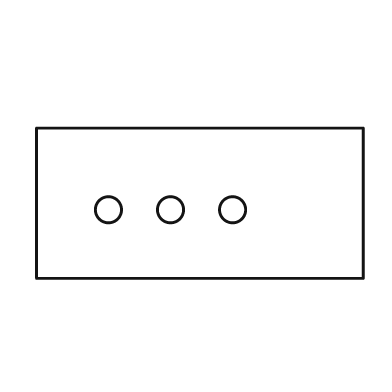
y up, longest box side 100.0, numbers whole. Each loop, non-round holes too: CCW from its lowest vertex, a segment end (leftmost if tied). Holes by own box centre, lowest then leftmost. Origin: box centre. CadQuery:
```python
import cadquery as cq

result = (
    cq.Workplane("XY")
    .moveTo(-50.0, -23.0)
    .lineTo(50.0, -23.0)
    .lineTo(50.0, 23.0)
    .lineTo(-50.0, 23.0)
    .close()
    .moveTo(-28.0, -2.0)
    .circle(4.0)
    .moveTo(-9.0, -2.0)
    .circle(4.0)
    .moveTo(10.0, -2.0)
    .circle(4.0)
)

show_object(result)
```